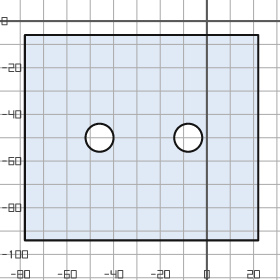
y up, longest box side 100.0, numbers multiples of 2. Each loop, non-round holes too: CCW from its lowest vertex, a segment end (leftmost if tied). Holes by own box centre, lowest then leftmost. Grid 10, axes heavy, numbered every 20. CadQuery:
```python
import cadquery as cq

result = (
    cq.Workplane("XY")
    .moveTo(-78.0, -94.0)
    .lineTo(22.0, -94.0)
    .lineTo(22.0, -6.0)
    .lineTo(-78.0, -6.0)
    .close()
    .moveTo(-46.0, -50.0)
    .circle(6.0)
    .moveTo(-8.0, -50.0)
    .circle(6.0)
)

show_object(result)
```